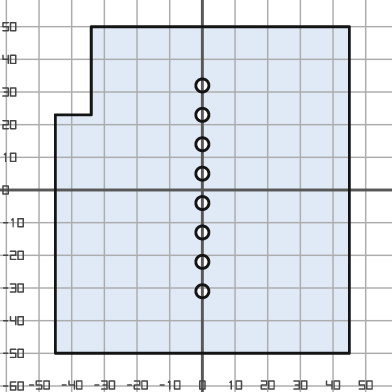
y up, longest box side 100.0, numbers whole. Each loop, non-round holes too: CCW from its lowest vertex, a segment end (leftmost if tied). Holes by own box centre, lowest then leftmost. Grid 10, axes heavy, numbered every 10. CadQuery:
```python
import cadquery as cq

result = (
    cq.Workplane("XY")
    .moveTo(-45.0, -50.0)
    .lineTo(45.0, -50.0)
    .lineTo(45.0, 50.0)
    .lineTo(-34.0, 50.0)
    .lineTo(-34.0, 23.0)
    .lineTo(-45.0, 23.0)
    .close()
    .moveTo(0.0, -31.0)
    .circle(2.0)
    .moveTo(0.0, -22.0)
    .circle(2.0)
    .moveTo(0.0, -13.0)
    .circle(2.0)
    .moveTo(0.0, -4.0)
    .circle(2.0)
    .moveTo(0.0, 5.0)
    .circle(2.0)
    .moveTo(0.0, 14.0)
    .circle(2.0)
    .moveTo(0.0, 23.0)
    .circle(2.0)
    .moveTo(0.0, 32.0)
    .circle(2.0)
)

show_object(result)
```